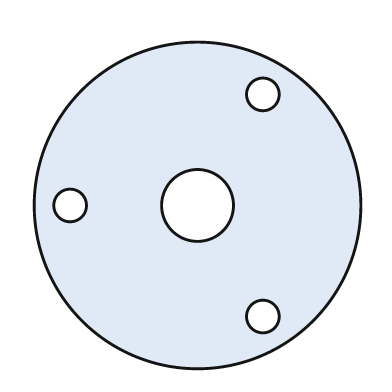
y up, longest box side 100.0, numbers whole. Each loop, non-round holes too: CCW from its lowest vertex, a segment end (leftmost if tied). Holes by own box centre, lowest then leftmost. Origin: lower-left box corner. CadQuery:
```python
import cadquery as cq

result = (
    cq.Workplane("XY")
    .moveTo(50.0, 50.0)
    .circle(50.0)
    .moveTo(70.0, 16.0)
    .circle(5.0)
    .moveTo(11.0, 50.0)
    .circle(5.0)
    .moveTo(50.0, 50.0)
    .circle(11.0)
    .moveTo(70.0, 84.0)
    .circle(5.0)
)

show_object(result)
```